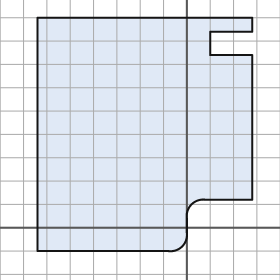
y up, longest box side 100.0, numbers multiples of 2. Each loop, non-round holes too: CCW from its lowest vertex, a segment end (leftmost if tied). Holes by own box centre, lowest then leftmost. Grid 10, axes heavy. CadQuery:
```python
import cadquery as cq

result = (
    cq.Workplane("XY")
    .moveTo(-64.0, -10.0)
    .lineTo(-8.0, -10.0)
    .threePointArc((-2.0, -8.0), (0.0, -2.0))
    .lineTo(0.0, 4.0)
    .threePointArc((2.0, 10.0), (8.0, 12.0))
    .lineTo(28.0, 12.0)
    .lineTo(28.0, 74.0)
    .lineTo(10.0, 74.0)
    .lineTo(10.0, 84.0)
    .lineTo(28.0, 84.0)
    .lineTo(28.0, 90.0)
    .lineTo(-64.0, 90.0)
    .close()
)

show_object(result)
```